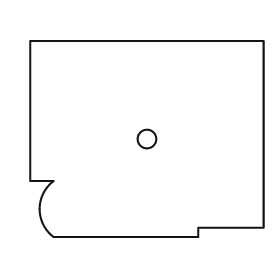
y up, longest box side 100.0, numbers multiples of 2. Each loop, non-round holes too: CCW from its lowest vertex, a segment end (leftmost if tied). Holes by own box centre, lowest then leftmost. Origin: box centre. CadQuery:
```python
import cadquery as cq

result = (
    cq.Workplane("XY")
    .moveTo(-40.0, -42.0)
    .lineTo(22.0, -42.0)
    .lineTo(22.0, -38.0)
    .lineTo(50.0, -38.0)
    .lineTo(50.0, 42.0)
    .lineTo(-50.0, 42.0)
    .lineTo(-50.0, -18.0)
    .lineTo(-40.0, -18.0)
    .threePointArc((-46.0, -30.0), (-40.0, -42.0))
    .close()
    .moveTo(0.0, 0.0)
    .circle(4.0)
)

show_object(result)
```